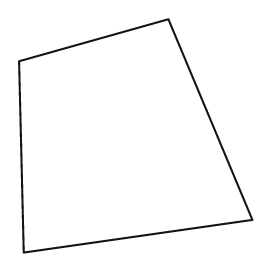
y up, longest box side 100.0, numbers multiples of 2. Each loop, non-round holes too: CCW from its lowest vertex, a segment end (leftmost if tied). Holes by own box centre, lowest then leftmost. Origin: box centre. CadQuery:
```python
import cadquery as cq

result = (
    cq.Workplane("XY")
    .moveTo(-48.0, -50.0)
    .lineTo(50.0, -36.0)
    .lineTo(14.0, 50.0)
    .lineTo(-50.0, 32.0)
    .close()
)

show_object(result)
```